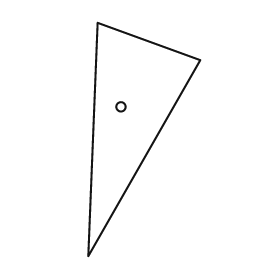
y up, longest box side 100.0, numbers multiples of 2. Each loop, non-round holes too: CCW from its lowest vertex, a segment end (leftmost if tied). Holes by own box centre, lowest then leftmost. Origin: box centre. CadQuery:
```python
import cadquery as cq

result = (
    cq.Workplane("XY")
    .moveTo(-24.0, -50.0)
    .lineTo(24.0, 34.0)
    .lineTo(-20.0, 50.0)
    .close()
    .moveTo(-10.0, 14.0)
    .circle(2.0)
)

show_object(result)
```